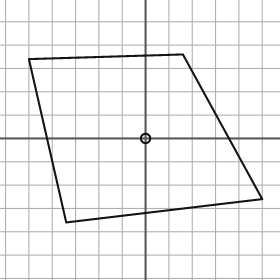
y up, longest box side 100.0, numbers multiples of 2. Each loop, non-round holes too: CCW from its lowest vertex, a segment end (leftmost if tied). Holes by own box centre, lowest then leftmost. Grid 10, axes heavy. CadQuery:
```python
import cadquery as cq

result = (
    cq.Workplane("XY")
    .moveTo(-34.0, -36.0)
    .lineTo(50.0, -26.0)
    .lineTo(16.0, 36.0)
    .lineTo(-50.0, 34.0)
    .close()
    .moveTo(0.0, 0.0)
    .circle(2.0)
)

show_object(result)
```